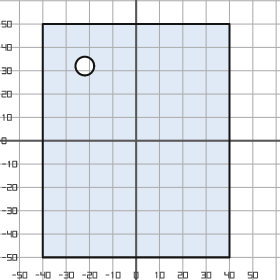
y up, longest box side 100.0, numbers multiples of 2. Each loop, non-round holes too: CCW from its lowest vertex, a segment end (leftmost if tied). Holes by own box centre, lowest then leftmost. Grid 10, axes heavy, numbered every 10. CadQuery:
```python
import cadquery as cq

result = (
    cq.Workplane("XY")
    .moveTo(-40.0, -50.0)
    .lineTo(40.0, -50.0)
    .lineTo(40.0, 50.0)
    .lineTo(-40.0, 50.0)
    .close()
    .moveTo(-22.0, 32.0)
    .circle(4.0)
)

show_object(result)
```